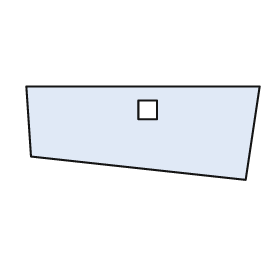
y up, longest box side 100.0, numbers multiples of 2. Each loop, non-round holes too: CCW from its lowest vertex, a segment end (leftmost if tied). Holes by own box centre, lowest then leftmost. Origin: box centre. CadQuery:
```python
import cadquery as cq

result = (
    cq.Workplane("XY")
    .moveTo(44.0, -20.0)
    .lineTo(50.0, 20.0)
    .lineTo(-50.0, 20.0)
    .lineTo(-48.0, -10.0)
    .close()
    .moveTo(-2.0, 6.0)
    .lineTo(6.0, 6.0)
    .lineTo(6.0, 14.0)
    .lineTo(-2.0, 14.0)
    .close()
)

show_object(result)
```